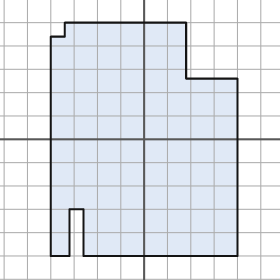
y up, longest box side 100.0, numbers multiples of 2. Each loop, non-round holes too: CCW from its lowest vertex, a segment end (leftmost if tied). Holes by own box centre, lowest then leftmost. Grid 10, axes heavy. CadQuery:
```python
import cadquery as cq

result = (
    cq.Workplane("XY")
    .moveTo(-40.0, -50.0)
    .lineTo(-32.0, -50.0)
    .lineTo(-32.0, -30.0)
    .lineTo(-26.0, -30.0)
    .lineTo(-26.0, -50.0)
    .lineTo(40.0, -50.0)
    .lineTo(40.0, 26.0)
    .lineTo(18.0, 26.0)
    .lineTo(18.0, 50.0)
    .lineTo(-34.0, 50.0)
    .lineTo(-34.0, 44.0)
    .lineTo(-40.0, 44.0)
    .close()
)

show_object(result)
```